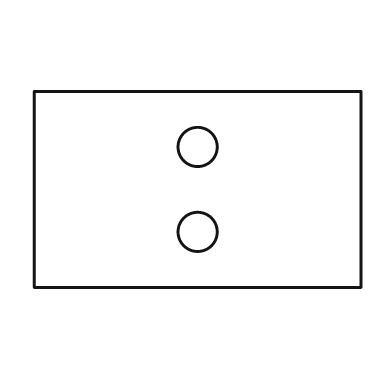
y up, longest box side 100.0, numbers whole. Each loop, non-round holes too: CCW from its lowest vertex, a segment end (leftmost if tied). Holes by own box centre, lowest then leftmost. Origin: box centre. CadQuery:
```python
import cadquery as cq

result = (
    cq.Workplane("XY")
    .moveTo(-50.0, -30.0)
    .lineTo(50.0, -30.0)
    .lineTo(50.0, 30.0)
    .lineTo(-50.0, 30.0)
    .close()
    .moveTo(0.0, -13.0)
    .circle(6.0)
    .moveTo(0.0, 13.0)
    .circle(6.0)
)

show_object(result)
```